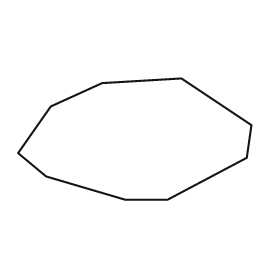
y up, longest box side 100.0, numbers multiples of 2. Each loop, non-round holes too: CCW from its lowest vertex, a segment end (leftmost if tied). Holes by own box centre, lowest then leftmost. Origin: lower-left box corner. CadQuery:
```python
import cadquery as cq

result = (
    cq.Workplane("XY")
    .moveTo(46.0, 0.0)
    .lineTo(64.0, 0.0)
    .lineTo(98.0, 18.0)
    .lineTo(100.0, 32.0)
    .lineTo(70.0, 52.0)
    .lineTo(36.0, 50.0)
    .lineTo(14.0, 40.0)
    .lineTo(0.0, 20.0)
    .lineTo(12.0, 10.0)
    .close()
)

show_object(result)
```